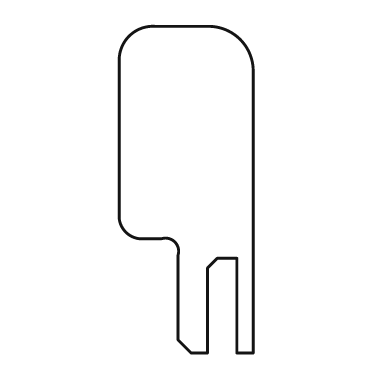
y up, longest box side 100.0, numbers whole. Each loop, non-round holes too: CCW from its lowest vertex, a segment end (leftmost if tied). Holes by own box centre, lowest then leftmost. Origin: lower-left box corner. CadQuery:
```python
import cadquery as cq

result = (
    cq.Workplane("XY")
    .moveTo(22.0, 0.0)
    .lineTo(27.0, 0.0)
    .lineTo(27.0, 26.0)
    .lineTo(30.0, 29.0)
    .lineTo(36.0, 29.0)
    .lineTo(36.0, 0.0)
    .lineTo(41.0, 0.0)
    .lineTo(41.0, 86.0)
    .threePointArc((37.0, 96.0), (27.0, 100.0))
    .lineTo(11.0, 100.0)
    .threePointArc((3.0, 97.0), (0.0, 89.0))
    .lineTo(0.0, 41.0)
    .threePointArc((2.0, 37.0), (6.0, 35.0))
    .lineTo(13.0, 35.0)
    .threePointArc((17.0, 34.0), (18.0, 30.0))
    .lineTo(18.0, 4.0)
    .close()
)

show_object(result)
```